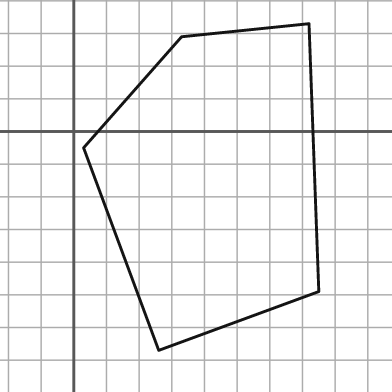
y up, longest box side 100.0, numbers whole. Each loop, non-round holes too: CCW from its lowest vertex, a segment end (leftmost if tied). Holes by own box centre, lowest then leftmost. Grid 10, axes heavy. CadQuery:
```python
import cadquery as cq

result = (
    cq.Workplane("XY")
    .moveTo(26.0, -67.0)
    .lineTo(75.0, -49.0)
    .lineTo(72.0, 33.0)
    .lineTo(33.0, 29.0)
    .lineTo(3.0, -5.0)
    .close()
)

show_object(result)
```